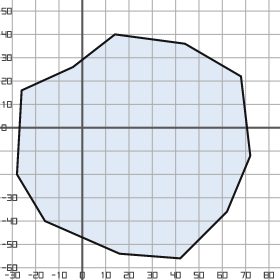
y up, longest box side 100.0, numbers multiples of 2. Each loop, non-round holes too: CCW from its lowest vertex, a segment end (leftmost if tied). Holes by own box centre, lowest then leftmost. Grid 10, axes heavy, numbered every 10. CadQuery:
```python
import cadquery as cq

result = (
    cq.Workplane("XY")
    .moveTo(42.0, -56.0)
    .lineTo(62.0, -36.0)
    .lineTo(72.0, -12.0)
    .lineTo(68.0, 22.0)
    .lineTo(44.0, 36.0)
    .lineTo(14.0, 40.0)
    .lineTo(-4.0, 26.0)
    .lineTo(-26.0, 16.0)
    .lineTo(-28.0, -20.0)
    .lineTo(-16.0, -40.0)
    .lineTo(16.0, -54.0)
    .close()
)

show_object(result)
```